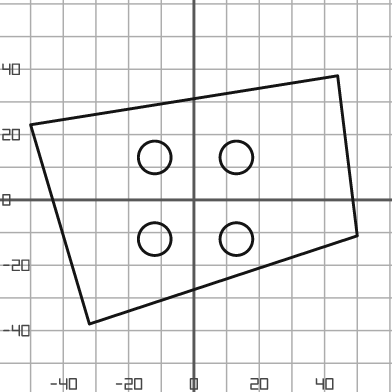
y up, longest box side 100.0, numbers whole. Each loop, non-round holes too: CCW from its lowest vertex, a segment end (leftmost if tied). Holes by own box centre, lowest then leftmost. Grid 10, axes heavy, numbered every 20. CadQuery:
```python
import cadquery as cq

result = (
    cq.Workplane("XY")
    .moveTo(-32.0, -38.0)
    .lineTo(50.0, -11.0)
    .lineTo(44.0, 38.0)
    .lineTo(-50.0, 23.0)
    .close()
    .moveTo(-12.0, -12.0)
    .circle(5.0)
    .moveTo(13.0, -12.0)
    .circle(5.0)
    .moveTo(-12.0, 13.0)
    .circle(5.0)
    .moveTo(13.0, 13.0)
    .circle(5.0)
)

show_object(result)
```